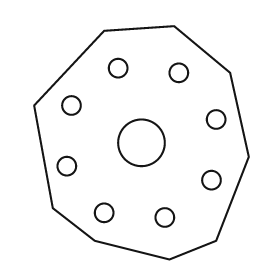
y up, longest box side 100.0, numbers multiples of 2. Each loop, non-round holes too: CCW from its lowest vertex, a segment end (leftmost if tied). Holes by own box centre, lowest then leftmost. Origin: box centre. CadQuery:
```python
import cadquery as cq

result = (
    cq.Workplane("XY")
    .moveTo(12.0, -50.0)
    .lineTo(32.0, -42.0)
    .lineTo(46.0, -6.0)
    .lineTo(38.0, 30.0)
    .lineTo(14.0, 50.0)
    .lineTo(-16.0, 48.0)
    .lineTo(-46.0, 16.0)
    .lineTo(-38.0, -28.0)
    .lineTo(-20.0, -42.0)
    .close()
    .moveTo(10.0, -32.0)
    .circle(4.0)
    .moveTo(-16.0, -30.0)
    .circle(4.0)
    .moveTo(30.0, -16.0)
    .circle(4.0)
    .moveTo(-32.0, -10.0)
    .circle(4.0)
    .moveTo(0.0, 0.0)
    .circle(10.0)
    .moveTo(32.0, 10.0)
    .circle(4.0)
    .moveTo(-30.0, 16.0)
    .circle(4.0)
    .moveTo(16.0, 30.0)
    .circle(4.0)
    .moveTo(-10.0, 32.0)
    .circle(4.0)
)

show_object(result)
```